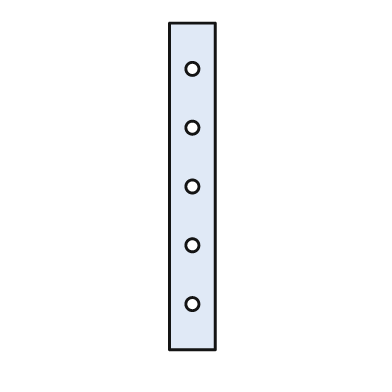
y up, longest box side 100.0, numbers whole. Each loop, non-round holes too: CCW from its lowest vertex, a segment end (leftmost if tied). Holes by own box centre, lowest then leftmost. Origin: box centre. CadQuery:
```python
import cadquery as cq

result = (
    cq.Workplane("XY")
    .moveTo(-7.0, -50.0)
    .lineTo(7.0, -50.0)
    .lineTo(7.0, 50.0)
    .lineTo(-7.0, 50.0)
    .close()
    .moveTo(0.0, -36.0)
    .circle(2.0)
    .moveTo(0.0, -18.0)
    .circle(2.0)
    .moveTo(0.0, 0.0)
    .circle(2.0)
    .moveTo(0.0, 18.0)
    .circle(2.0)
    .moveTo(0.0, 36.0)
    .circle(2.0)
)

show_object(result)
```